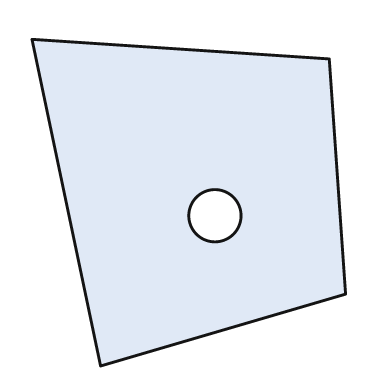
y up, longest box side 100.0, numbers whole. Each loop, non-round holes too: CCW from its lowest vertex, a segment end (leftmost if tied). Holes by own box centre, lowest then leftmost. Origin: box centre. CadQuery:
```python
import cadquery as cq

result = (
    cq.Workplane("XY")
    .moveTo(-27.0, -50.0)
    .lineTo(48.0, -28.0)
    .lineTo(43.0, 44.0)
    .lineTo(-48.0, 50.0)
    .close()
    .moveTo(8.0, -4.0)
    .circle(8.0)
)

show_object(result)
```